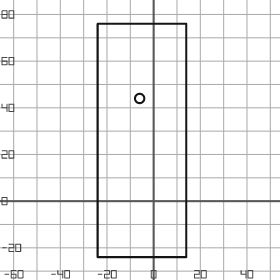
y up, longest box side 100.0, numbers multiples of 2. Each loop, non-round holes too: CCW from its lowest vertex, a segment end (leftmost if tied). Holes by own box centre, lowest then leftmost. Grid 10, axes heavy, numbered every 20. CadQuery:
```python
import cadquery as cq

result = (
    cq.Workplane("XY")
    .moveTo(-24.0, -24.0)
    .lineTo(14.0, -24.0)
    .lineTo(14.0, 76.0)
    .lineTo(-24.0, 76.0)
    .close()
    .moveTo(-6.0, 44.0)
    .circle(2.0)
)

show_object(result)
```